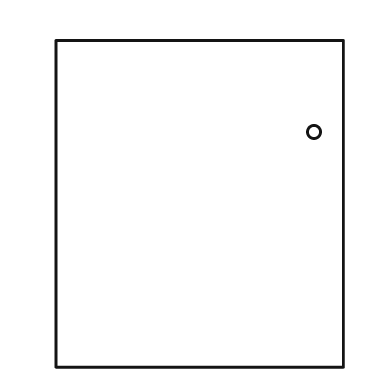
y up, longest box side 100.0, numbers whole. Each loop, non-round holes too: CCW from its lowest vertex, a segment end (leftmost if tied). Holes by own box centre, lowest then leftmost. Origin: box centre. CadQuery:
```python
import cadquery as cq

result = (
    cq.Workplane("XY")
    .moveTo(-44.0, -50.0)
    .lineTo(44.0, -50.0)
    .lineTo(44.0, 50.0)
    .lineTo(-44.0, 50.0)
    .close()
    .moveTo(35.0, 22.0)
    .circle(2.0)
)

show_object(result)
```